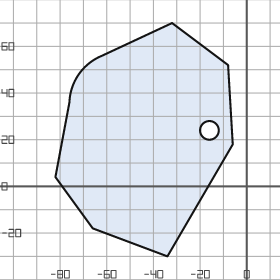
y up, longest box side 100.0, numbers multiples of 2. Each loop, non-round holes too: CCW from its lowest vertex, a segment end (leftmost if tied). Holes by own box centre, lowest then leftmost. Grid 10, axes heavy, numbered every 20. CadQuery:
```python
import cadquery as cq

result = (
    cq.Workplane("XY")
    .moveTo(-34.0, -30.0)
    .lineTo(-6.0, 18.0)
    .lineTo(-8.0, 52.0)
    .lineTo(-32.0, 70.0)
    .lineTo(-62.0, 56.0)
    .threePointArc((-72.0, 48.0), (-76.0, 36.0))
    .lineTo(-82.0, 4.0)
    .lineTo(-66.0, -18.0)
    .close()
    .moveTo(-16.0, 24.0)
    .circle(4.0)
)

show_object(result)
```